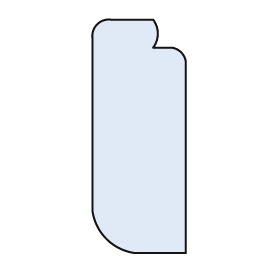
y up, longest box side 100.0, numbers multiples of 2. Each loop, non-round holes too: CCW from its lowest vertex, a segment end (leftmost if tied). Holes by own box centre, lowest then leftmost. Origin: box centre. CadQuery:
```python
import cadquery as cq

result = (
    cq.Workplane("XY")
    .moveTo(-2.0, -50.0)
    .lineTo(20.0, -50.0)
    .lineTo(20.0, 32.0)
    .threePointArc((18.0, 36.0), (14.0, 38.0))
    .lineTo(6.0, 38.0)
    .threePointArc((8.0, 44.0), (6.0, 50.0))
    .lineTo(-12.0, 50.0)
    .threePointArc((-18.0, 48.0), (-20.0, 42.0))
    .lineTo(-20.0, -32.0)
    .threePointArc((-14.0, -44.0), (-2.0, -50.0))
    .close()
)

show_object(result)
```